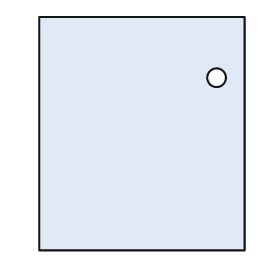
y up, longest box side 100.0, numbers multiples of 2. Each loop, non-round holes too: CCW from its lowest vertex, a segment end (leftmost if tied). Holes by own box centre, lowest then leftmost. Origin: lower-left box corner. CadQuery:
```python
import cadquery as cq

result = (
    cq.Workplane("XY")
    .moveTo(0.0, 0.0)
    .lineTo(88.0, 0.0)
    .lineTo(88.0, 100.0)
    .lineTo(0.0, 100.0)
    .close()
    .moveTo(76.0, 74.0)
    .circle(4.0)
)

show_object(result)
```